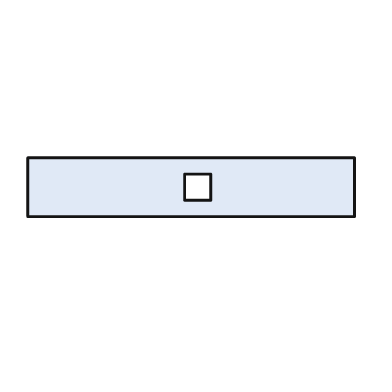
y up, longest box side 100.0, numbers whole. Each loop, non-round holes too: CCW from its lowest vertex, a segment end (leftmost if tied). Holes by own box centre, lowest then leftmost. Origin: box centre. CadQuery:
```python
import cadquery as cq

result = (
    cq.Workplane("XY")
    .moveTo(-50.0, -9.0)
    .lineTo(50.0, -9.0)
    .lineTo(50.0, 9.0)
    .lineTo(-50.0, 9.0)
    .close()
    .moveTo(-2.0, -4.0)
    .lineTo(6.0, -4.0)
    .lineTo(6.0, 4.0)
    .lineTo(-2.0, 4.0)
    .close()
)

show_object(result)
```